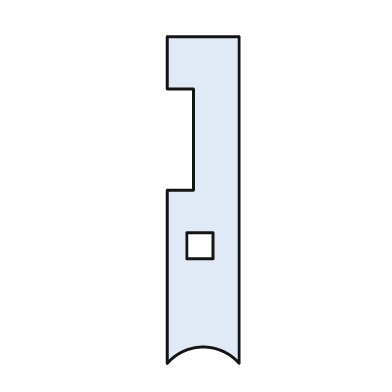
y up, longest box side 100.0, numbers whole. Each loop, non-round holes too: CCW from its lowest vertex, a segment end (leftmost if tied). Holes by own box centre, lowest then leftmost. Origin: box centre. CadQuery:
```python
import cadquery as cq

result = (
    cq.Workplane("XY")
    .moveTo(-11.0, -50.0)
    .threePointArc((0.0, -45.0), (11.0, -50.0))
    .lineTo(11.0, 50.0)
    .lineTo(-11.0, 50.0)
    .lineTo(-11.0, 34.0)
    .lineTo(-3.0, 34.0)
    .lineTo(-3.0, 3.0)
    .lineTo(-11.0, 3.0)
    .close()
    .moveTo(-5.0, -18.0)
    .lineTo(3.0, -18.0)
    .lineTo(3.0, -10.0)
    .lineTo(-5.0, -10.0)
    .close()
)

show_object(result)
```